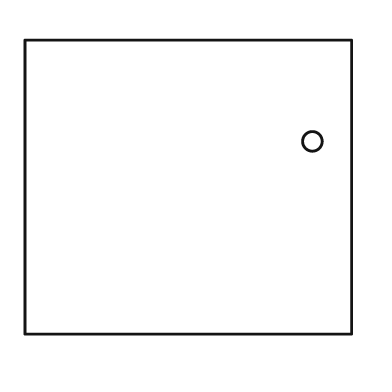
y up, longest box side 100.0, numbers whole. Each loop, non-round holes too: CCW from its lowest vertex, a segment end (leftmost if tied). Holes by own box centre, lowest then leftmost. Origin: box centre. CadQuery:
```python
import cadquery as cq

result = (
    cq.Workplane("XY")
    .moveTo(-50.0, -45.0)
    .lineTo(50.0, -45.0)
    .lineTo(50.0, 45.0)
    .lineTo(-50.0, 45.0)
    .close()
    .moveTo(38.0, 14.0)
    .circle(3.0)
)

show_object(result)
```